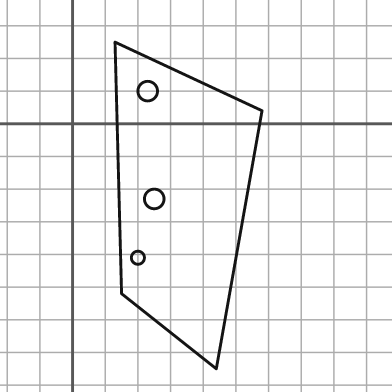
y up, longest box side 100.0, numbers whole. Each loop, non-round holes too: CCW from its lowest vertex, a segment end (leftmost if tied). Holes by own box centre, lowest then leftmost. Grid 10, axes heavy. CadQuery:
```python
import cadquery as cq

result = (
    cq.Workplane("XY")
    .moveTo(44.0, -75.0)
    .lineTo(58.0, 4.0)
    .lineTo(13.0, 25.0)
    .lineTo(15.0, -52.0)
    .close()
    .moveTo(20.0, -41.0)
    .circle(2.0)
    .moveTo(25.0, -23.0)
    .circle(3.0)
    .moveTo(23.0, 10.0)
    .circle(3.0)
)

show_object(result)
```